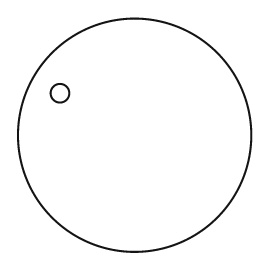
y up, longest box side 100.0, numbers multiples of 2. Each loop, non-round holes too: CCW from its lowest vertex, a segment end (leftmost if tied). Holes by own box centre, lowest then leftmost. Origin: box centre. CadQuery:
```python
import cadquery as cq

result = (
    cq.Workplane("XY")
    .moveTo(0.0, 0.0)
    .circle(50.0)
    .moveTo(-32.0, 18.0)
    .circle(4.0)
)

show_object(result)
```